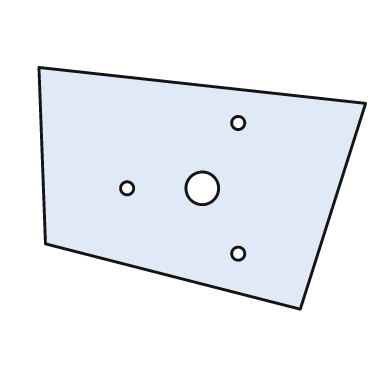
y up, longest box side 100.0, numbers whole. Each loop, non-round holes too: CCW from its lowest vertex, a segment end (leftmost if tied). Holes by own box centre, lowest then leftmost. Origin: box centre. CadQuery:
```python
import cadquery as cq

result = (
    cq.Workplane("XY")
    .moveTo(30.0, -37.0)
    .lineTo(50.0, 26.0)
    .lineTo(-50.0, 37.0)
    .lineTo(-48.0, -17.0)
    .close()
    .moveTo(11.0, -20.0)
    .circle(2.0)
    .moveTo(-23.0, 0.0)
    .circle(2.0)
    .moveTo(0.0, 0.0)
    .circle(5.0)
    .moveTo(11.0, 20.0)
    .circle(2.0)
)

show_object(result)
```